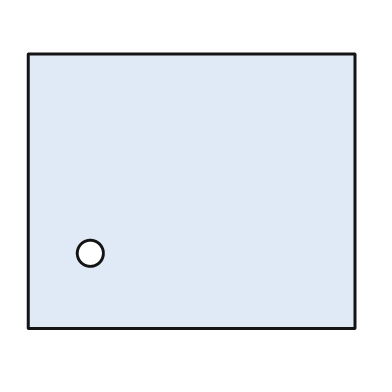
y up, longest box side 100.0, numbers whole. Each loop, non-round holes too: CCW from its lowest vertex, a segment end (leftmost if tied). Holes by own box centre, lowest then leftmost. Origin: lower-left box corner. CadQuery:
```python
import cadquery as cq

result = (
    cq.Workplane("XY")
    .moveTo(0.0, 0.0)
    .lineTo(100.0, 0.0)
    .lineTo(100.0, 84.0)
    .lineTo(0.0, 84.0)
    .close()
    .moveTo(19.0, 23.0)
    .circle(4.0)
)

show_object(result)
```